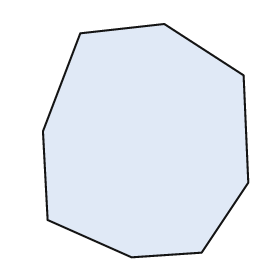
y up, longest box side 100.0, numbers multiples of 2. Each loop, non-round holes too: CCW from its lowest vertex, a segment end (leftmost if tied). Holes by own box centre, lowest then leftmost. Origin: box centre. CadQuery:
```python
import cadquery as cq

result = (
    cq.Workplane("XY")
    .moveTo(-6.0, -50.0)
    .lineTo(24.0, -48.0)
    .lineTo(44.0, -18.0)
    .lineTo(42.0, 28.0)
    .lineTo(8.0, 50.0)
    .lineTo(-28.0, 46.0)
    .lineTo(-44.0, 4.0)
    .lineTo(-42.0, -34.0)
    .close()
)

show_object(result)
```